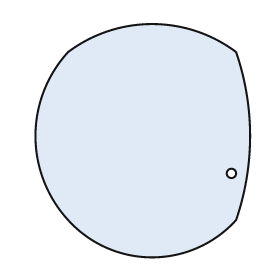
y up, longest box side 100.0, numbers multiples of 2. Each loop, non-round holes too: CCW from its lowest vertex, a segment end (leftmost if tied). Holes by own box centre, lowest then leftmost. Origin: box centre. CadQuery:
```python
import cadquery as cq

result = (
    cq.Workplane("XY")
    .moveTo(-32.0, -34.0)
    .threePointArc((4.0, -50.0), (40.0, -34.0))
    .threePointArc((46.0, 2.0), (40.0, 38.0))
    .threePointArc((4.0, 50.0), (-32.0, 38.0))
    .threePointArc((-46.0, 2.0), (-32.0, -34.0))
    .close()
    .moveTo(38.0, -14.0)
    .circle(2.0)
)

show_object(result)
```